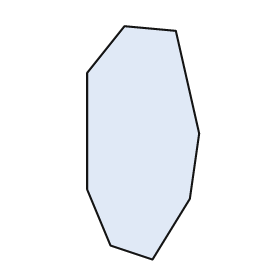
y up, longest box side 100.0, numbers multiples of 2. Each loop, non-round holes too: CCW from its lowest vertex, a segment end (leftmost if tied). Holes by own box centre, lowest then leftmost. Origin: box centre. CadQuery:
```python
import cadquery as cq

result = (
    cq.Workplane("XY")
    .moveTo(4.0, -50.0)
    .lineTo(20.0, -24.0)
    .lineTo(24.0, 4.0)
    .lineTo(14.0, 48.0)
    .lineTo(-8.0, 50.0)
    .lineTo(-24.0, 30.0)
    .lineTo(-24.0, -20.0)
    .lineTo(-14.0, -44.0)
    .close()
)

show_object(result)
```